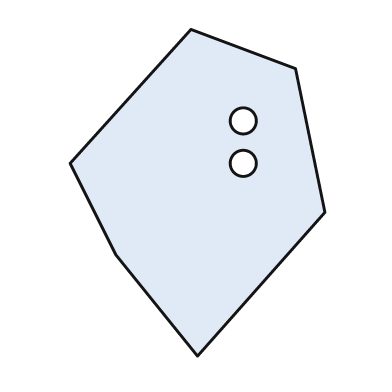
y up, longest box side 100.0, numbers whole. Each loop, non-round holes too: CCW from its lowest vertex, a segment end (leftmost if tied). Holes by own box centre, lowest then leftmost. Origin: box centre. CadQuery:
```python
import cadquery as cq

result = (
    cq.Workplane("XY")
    .moveTo(0.0, -50.0)
    .lineTo(39.0, -6.0)
    .lineTo(30.0, 38.0)
    .lineTo(-2.0, 50.0)
    .lineTo(-39.0, 9.0)
    .lineTo(-25.0, -19.0)
    .close()
    .moveTo(14.0, 9.0)
    .circle(4.0)
    .moveTo(14.0, 22.0)
    .circle(4.0)
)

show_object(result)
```